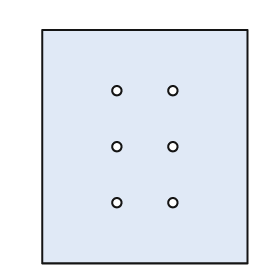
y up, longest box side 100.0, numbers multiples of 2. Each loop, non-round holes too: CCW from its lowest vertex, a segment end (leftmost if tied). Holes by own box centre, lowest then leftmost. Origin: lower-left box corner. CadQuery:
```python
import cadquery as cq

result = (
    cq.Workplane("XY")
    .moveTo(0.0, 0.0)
    .lineTo(88.0, 0.0)
    .lineTo(88.0, 100.0)
    .lineTo(0.0, 100.0)
    .close()
    .moveTo(32.0, 26.0)
    .circle(2.0)
    .moveTo(56.0, 26.0)
    .circle(2.0)
    .moveTo(32.0, 50.0)
    .circle(2.0)
    .moveTo(56.0, 50.0)
    .circle(2.0)
    .moveTo(32.0, 74.0)
    .circle(2.0)
    .moveTo(56.0, 74.0)
    .circle(2.0)
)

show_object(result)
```